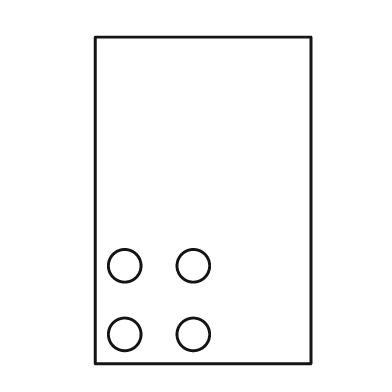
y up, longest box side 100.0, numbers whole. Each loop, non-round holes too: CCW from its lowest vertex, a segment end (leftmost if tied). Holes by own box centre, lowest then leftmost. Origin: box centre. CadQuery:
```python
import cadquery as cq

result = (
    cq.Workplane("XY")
    .moveTo(-33.0, -50.0)
    .lineTo(33.0, -50.0)
    .lineTo(33.0, 50.0)
    .lineTo(-33.0, 50.0)
    .close()
    .moveTo(-24.0, -41.0)
    .circle(5.0)
    .moveTo(-3.0, -41.0)
    .circle(5.0)
    .moveTo(-24.0, -20.0)
    .circle(5.0)
    .moveTo(-3.0, -20.0)
    .circle(5.0)
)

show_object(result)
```